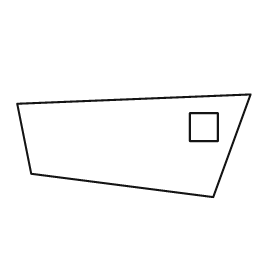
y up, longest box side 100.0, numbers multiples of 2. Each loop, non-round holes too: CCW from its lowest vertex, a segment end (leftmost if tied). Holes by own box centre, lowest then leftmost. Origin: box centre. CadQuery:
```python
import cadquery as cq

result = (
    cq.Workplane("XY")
    .moveTo(34.0, -22.0)
    .lineTo(50.0, 22.0)
    .lineTo(-50.0, 18.0)
    .lineTo(-44.0, -12.0)
    .close()
    .moveTo(24.0, 2.0)
    .lineTo(36.0, 2.0)
    .lineTo(36.0, 14.0)
    .lineTo(24.0, 14.0)
    .close()
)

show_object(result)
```